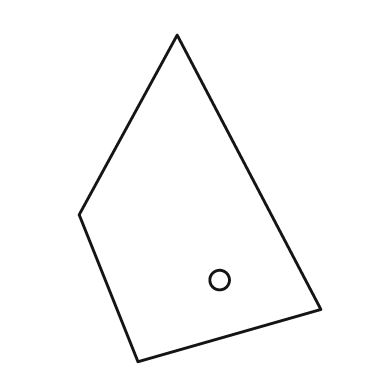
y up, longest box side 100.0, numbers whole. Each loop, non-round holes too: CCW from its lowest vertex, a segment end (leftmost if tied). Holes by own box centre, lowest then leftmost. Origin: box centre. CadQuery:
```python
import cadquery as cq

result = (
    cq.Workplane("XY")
    .moveTo(-19.0, -50.0)
    .lineTo(37.0, -34.0)
    .lineTo(-7.0, 50.0)
    .lineTo(-37.0, -5.0)
    .close()
    .moveTo(6.0, -25.0)
    .circle(3.0)
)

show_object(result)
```